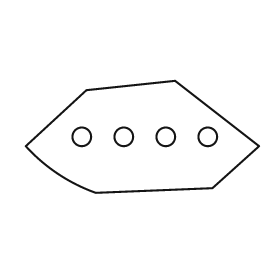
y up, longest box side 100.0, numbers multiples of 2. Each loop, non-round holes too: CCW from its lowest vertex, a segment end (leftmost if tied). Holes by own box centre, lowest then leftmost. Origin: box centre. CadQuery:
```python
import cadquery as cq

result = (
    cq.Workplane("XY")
    .moveTo(-20.0, -24.0)
    .lineTo(30.0, -22.0)
    .lineTo(50.0, -4.0)
    .lineTo(14.0, 24.0)
    .lineTo(-24.0, 20.0)
    .lineTo(-50.0, -4.0)
    .threePointArc((-36.0, -16.0), (-20.0, -24.0))
    .close()
    .moveTo(-26.0, 0.0)
    .circle(4.0)
    .moveTo(-8.0, 0.0)
    .circle(4.0)
    .moveTo(10.0, 0.0)
    .circle(4.0)
    .moveTo(28.0, 0.0)
    .circle(4.0)
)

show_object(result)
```